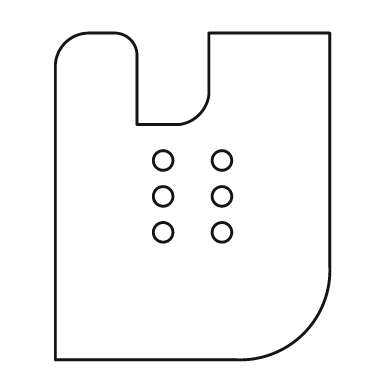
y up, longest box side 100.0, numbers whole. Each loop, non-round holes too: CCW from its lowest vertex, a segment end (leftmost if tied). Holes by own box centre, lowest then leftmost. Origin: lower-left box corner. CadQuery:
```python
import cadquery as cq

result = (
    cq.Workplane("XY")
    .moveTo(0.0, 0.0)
    .lineTo(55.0, 0.0)
    .threePointArc((76.0, 8.0), (84.0, 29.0))
    .lineTo(84.0, 100.0)
    .lineTo(47.0, 100.0)
    .lineTo(47.0, 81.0)
    .threePointArc((44.0, 75.0), (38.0, 72.0))
    .lineTo(25.0, 72.0)
    .lineTo(25.0, 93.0)
    .threePointArc((23.0, 98.0), (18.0, 100.0))
    .lineTo(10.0, 100.0)
    .threePointArc((3.0, 97.0), (0.0, 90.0))
    .close()
    .moveTo(33.0, 39.0)
    .circle(3.0)
    .moveTo(51.0, 39.0)
    .circle(3.0)
    .moveTo(33.0, 50.0)
    .circle(3.0)
    .moveTo(51.0, 50.0)
    .circle(3.0)
    .moveTo(33.0, 61.0)
    .circle(3.0)
    .moveTo(51.0, 61.0)
    .circle(3.0)
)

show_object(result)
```